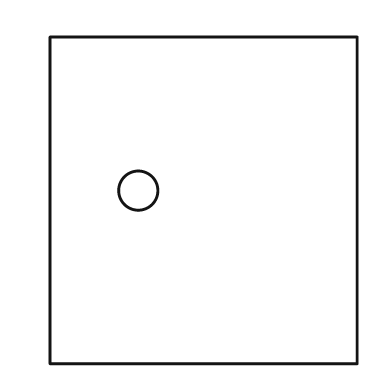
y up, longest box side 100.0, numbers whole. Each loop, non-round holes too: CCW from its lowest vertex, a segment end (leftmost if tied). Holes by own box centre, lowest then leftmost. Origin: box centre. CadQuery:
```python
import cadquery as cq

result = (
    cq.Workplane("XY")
    .moveTo(-47.0, -50.0)
    .lineTo(47.0, -50.0)
    .lineTo(47.0, 50.0)
    .lineTo(-47.0, 50.0)
    .close()
    .moveTo(-20.0, 3.0)
    .circle(6.0)
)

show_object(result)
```